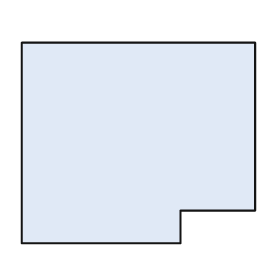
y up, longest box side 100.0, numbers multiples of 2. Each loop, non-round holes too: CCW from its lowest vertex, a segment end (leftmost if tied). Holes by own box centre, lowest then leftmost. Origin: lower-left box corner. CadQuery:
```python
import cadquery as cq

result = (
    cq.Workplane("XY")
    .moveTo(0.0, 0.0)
    .lineTo(68.0, 0.0)
    .lineTo(68.0, 14.0)
    .lineTo(100.0, 14.0)
    .lineTo(100.0, 86.0)
    .lineTo(0.0, 86.0)
    .close()
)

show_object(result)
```